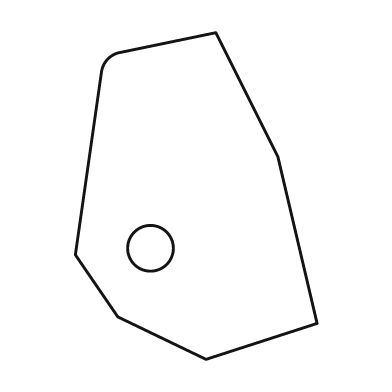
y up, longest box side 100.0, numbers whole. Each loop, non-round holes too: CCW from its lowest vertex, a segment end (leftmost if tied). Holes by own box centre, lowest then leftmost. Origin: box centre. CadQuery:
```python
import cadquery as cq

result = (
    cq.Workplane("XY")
    .moveTo(3.0, -50.0)
    .lineTo(37.0, -39.0)
    .lineTo(25.0, 12.0)
    .lineTo(6.0, 50.0)
    .lineTo(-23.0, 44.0)
    .threePointArc((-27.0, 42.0), (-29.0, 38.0))
    .lineTo(-37.0, -18.0)
    .lineTo(-24.0, -37.0)
    .close()
    .moveTo(-14.0, -16.0)
    .circle(7.0)
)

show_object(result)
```